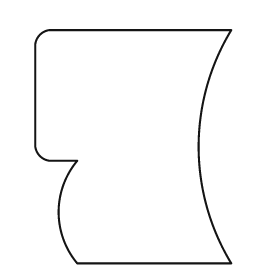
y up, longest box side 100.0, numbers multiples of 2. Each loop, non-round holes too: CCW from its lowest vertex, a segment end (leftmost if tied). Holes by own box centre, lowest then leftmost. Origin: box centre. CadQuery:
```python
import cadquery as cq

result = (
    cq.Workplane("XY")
    .moveTo(-24.0, -50.0)
    .lineTo(42.0, -50.0)
    .threePointArc((28.0, 0.0), (42.0, 50.0))
    .lineTo(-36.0, 50.0)
    .threePointArc((-40.0, 48.0), (-42.0, 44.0))
    .lineTo(-42.0, 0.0)
    .threePointArc((-40.0, -4.0), (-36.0, -6.0))
    .lineTo(-24.0, -6.0)
    .threePointArc((-32.0, -28.0), (-24.0, -50.0))
    .close()
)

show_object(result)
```